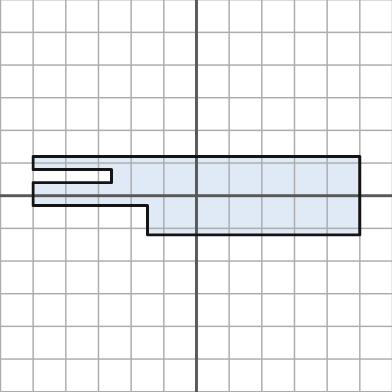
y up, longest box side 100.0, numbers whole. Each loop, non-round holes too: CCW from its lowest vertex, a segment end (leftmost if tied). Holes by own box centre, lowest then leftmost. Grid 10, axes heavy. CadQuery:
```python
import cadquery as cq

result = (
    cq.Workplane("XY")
    .moveTo(-15.0, -12.0)
    .lineTo(50.0, -12.0)
    .lineTo(50.0, 12.0)
    .lineTo(-50.0, 12.0)
    .lineTo(-50.0, 8.0)
    .lineTo(-26.0, 8.0)
    .lineTo(-26.0, 4.0)
    .lineTo(-50.0, 4.0)
    .lineTo(-50.0, -3.0)
    .lineTo(-15.0, -3.0)
    .close()
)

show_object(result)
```